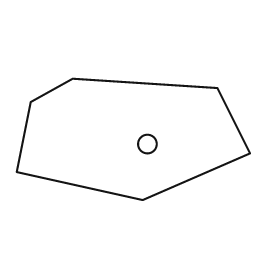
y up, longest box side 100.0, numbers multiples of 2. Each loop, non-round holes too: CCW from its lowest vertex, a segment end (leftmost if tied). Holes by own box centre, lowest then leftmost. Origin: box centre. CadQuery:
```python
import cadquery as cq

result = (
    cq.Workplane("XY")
    .moveTo(4.0, -26.0)
    .lineTo(50.0, -6.0)
    .lineTo(36.0, 22.0)
    .lineTo(-26.0, 26.0)
    .lineTo(-44.0, 16.0)
    .lineTo(-50.0, -14.0)
    .close()
    .moveTo(6.0, -2.0)
    .circle(4.0)
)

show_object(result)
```